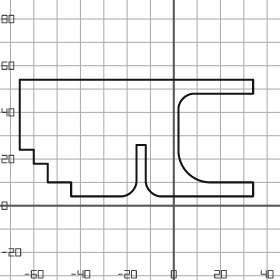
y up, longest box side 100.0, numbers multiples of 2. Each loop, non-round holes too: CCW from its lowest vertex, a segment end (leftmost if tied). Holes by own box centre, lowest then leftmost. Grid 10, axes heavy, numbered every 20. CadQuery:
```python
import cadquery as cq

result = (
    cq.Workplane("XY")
    .moveTo(-44.0, 4.0)
    .lineTo(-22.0, 4.0)
    .threePointArc((-18.0, 6.0), (-16.0, 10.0))
    .lineTo(-16.0, 26.0)
    .lineTo(-12.0, 26.0)
    .lineTo(-12.0, 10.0)
    .threePointArc((-10.0, 6.0), (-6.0, 4.0))
    .lineTo(34.0, 4.0)
    .lineTo(34.0, 10.0)
    .lineTo(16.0, 10.0)
    .threePointArc((6.0, 14.0), (2.0, 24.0))
    .lineTo(2.0, 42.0)
    .threePointArc((4.0, 46.0), (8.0, 48.0))
    .lineTo(34.0, 48.0)
    .lineTo(34.0, 54.0)
    .lineTo(-66.0, 54.0)
    .lineTo(-66.0, 24.0)
    .lineTo(-60.0, 24.0)
    .lineTo(-60.0, 18.0)
    .lineTo(-54.0, 18.0)
    .lineTo(-54.0, 10.0)
    .lineTo(-44.0, 10.0)
    .close()
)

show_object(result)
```